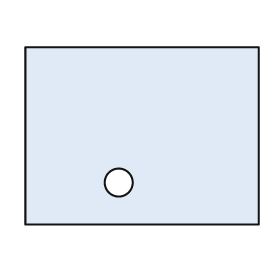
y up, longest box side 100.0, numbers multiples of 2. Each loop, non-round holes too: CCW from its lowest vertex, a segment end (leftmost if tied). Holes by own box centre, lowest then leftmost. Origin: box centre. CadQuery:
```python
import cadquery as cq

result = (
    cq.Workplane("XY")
    .moveTo(-50.0, -38.0)
    .lineTo(50.0, -38.0)
    .lineTo(50.0, 38.0)
    .lineTo(-50.0, 38.0)
    .close()
    .moveTo(-10.0, -20.0)
    .circle(6.0)
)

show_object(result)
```